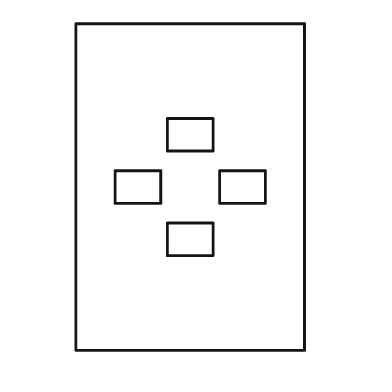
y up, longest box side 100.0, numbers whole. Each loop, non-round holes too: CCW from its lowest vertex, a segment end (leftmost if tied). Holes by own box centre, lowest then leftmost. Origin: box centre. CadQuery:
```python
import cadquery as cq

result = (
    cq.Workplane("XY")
    .moveTo(-35.0, -50.0)
    .lineTo(35.0, -50.0)
    .lineTo(35.0, 50.0)
    .lineTo(-35.0, 50.0)
    .close()
    .moveTo(-7.0, -21.0)
    .lineTo(7.0, -21.0)
    .lineTo(7.0, -11.0)
    .lineTo(-7.0, -11.0)
    .close()
    .moveTo(-23.0, -5.0)
    .lineTo(-9.0, -5.0)
    .lineTo(-9.0, 5.0)
    .lineTo(-23.0, 5.0)
    .close()
    .moveTo(9.0, -5.0)
    .lineTo(23.0, -5.0)
    .lineTo(23.0, 5.0)
    .lineTo(9.0, 5.0)
    .close()
    .moveTo(-7.0, 11.0)
    .lineTo(7.0, 11.0)
    .lineTo(7.0, 21.0)
    .lineTo(-7.0, 21.0)
    .close()
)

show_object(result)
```